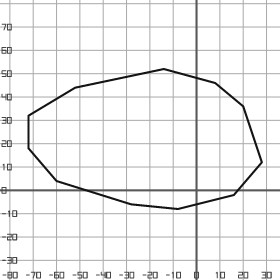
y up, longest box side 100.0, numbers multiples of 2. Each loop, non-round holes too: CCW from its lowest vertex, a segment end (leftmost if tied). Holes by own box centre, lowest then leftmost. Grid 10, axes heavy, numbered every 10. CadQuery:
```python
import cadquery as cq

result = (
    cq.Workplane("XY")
    .moveTo(-8.0, -8.0)
    .lineTo(16.0, -2.0)
    .lineTo(28.0, 12.0)
    .lineTo(20.0, 36.0)
    .lineTo(8.0, 46.0)
    .lineTo(-14.0, 52.0)
    .lineTo(-52.0, 44.0)
    .lineTo(-72.0, 32.0)
    .lineTo(-72.0, 18.0)
    .lineTo(-60.0, 4.0)
    .lineTo(-28.0, -6.0)
    .close()
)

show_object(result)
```